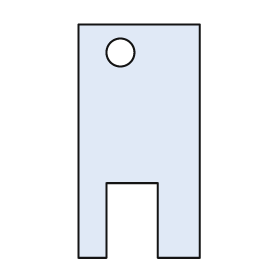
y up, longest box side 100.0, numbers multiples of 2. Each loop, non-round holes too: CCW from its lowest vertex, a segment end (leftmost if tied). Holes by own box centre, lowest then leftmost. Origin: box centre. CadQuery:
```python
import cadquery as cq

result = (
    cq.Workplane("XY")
    .moveTo(-26.0, -50.0)
    .lineTo(-14.0, -50.0)
    .lineTo(-14.0, -18.0)
    .lineTo(8.0, -18.0)
    .lineTo(8.0, -50.0)
    .lineTo(26.0, -50.0)
    .lineTo(26.0, 50.0)
    .lineTo(-26.0, 50.0)
    .close()
    .moveTo(-8.0, 38.0)
    .circle(6.0)
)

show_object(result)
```